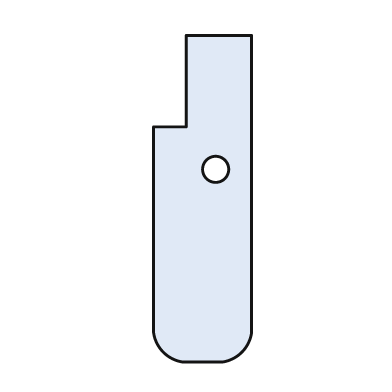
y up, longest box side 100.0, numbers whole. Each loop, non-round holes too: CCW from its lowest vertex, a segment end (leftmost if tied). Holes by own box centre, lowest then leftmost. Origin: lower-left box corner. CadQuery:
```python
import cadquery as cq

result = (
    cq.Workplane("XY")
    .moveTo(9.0, 0.0)
    .lineTo(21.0, 0.0)
    .threePointArc((27.0, 3.0), (30.0, 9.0))
    .lineTo(30.0, 100.0)
    .lineTo(10.0, 100.0)
    .lineTo(10.0, 72.0)
    .lineTo(0.0, 72.0)
    .lineTo(0.0, 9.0)
    .threePointArc((3.0, 3.0), (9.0, 0.0))
    .close()
    .moveTo(19.0, 59.0)
    .circle(4.0)
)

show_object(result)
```